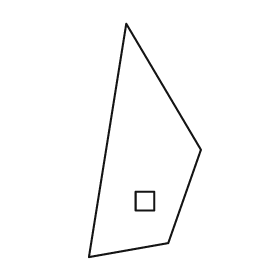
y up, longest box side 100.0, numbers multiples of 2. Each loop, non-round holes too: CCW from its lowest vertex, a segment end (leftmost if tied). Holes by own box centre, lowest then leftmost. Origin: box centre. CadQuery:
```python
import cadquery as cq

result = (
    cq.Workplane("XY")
    .moveTo(-24.0, -50.0)
    .lineTo(10.0, -44.0)
    .lineTo(24.0, -4.0)
    .lineTo(-8.0, 50.0)
    .close()
    .moveTo(-4.0, -30.0)
    .lineTo(4.0, -30.0)
    .lineTo(4.0, -22.0)
    .lineTo(-4.0, -22.0)
    .close()
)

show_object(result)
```